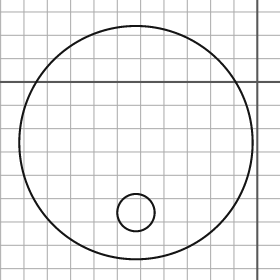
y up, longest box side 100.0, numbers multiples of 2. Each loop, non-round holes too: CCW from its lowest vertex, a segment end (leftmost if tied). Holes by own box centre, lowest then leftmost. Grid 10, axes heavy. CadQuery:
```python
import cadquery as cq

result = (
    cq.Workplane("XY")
    .moveTo(-52.0, -26.0)
    .circle(50.0)
    .moveTo(-52.0, -56.0)
    .circle(8.0)
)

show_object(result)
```